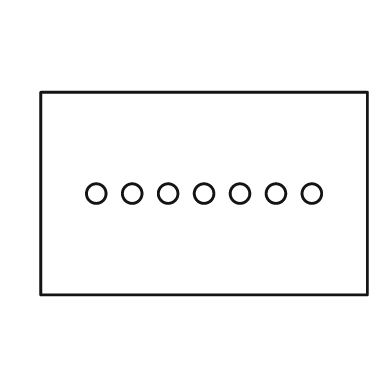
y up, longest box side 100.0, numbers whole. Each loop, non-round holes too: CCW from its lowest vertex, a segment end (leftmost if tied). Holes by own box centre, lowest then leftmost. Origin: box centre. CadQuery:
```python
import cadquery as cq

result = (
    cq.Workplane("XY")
    .moveTo(-50.0, -31.0)
    .lineTo(50.0, -31.0)
    .lineTo(50.0, 31.0)
    .lineTo(-50.0, 31.0)
    .close()
    .moveTo(-33.0, 0.0)
    .circle(3.0)
    .moveTo(-22.0, 0.0)
    .circle(3.0)
    .moveTo(-11.0, 0.0)
    .circle(3.0)
    .moveTo(0.0, 0.0)
    .circle(3.0)
    .moveTo(11.0, 0.0)
    .circle(3.0)
    .moveTo(22.0, 0.0)
    .circle(3.0)
    .moveTo(33.0, 0.0)
    .circle(3.0)
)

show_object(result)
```